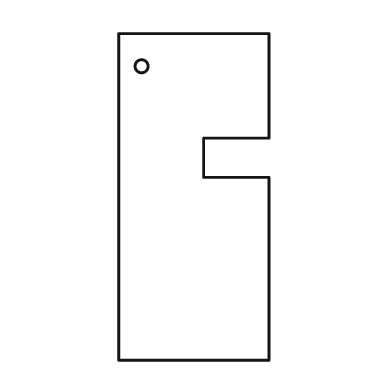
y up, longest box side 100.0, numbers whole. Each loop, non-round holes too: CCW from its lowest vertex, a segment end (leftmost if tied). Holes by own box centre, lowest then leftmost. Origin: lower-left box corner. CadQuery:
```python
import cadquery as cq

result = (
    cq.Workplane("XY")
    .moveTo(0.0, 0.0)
    .lineTo(46.0, 0.0)
    .lineTo(46.0, 56.0)
    .lineTo(26.0, 56.0)
    .lineTo(26.0, 68.0)
    .lineTo(46.0, 68.0)
    .lineTo(46.0, 100.0)
    .lineTo(0.0, 100.0)
    .close()
    .moveTo(7.0, 90.0)
    .circle(2.0)
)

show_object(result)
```